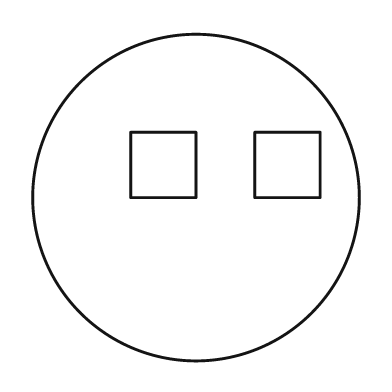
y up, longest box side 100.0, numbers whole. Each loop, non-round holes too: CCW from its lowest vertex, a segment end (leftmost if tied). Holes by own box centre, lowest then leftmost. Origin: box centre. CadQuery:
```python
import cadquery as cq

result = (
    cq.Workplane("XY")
    .moveTo(0.0, 0.0)
    .circle(50.0)
    .moveTo(-20.0, 0.0)
    .lineTo(0.0, 0.0)
    .lineTo(0.0, 20.0)
    .lineTo(-20.0, 20.0)
    .close()
    .moveTo(18.0, 0.0)
    .lineTo(38.0, 0.0)
    .lineTo(38.0, 20.0)
    .lineTo(18.0, 20.0)
    .close()
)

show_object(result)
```